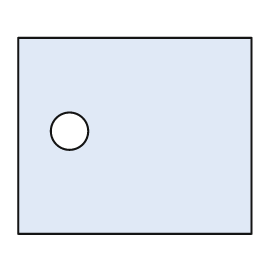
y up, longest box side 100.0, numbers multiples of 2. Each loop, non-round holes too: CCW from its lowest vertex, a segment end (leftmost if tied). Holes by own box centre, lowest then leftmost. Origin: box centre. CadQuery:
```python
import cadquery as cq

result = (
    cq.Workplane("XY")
    .moveTo(-50.0, -42.0)
    .lineTo(50.0, -42.0)
    .lineTo(50.0, 42.0)
    .lineTo(-50.0, 42.0)
    .close()
    .moveTo(-28.0, 2.0)
    .circle(8.0)
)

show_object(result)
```